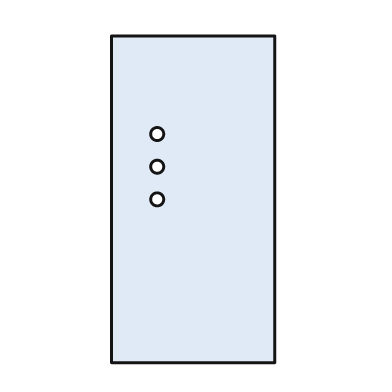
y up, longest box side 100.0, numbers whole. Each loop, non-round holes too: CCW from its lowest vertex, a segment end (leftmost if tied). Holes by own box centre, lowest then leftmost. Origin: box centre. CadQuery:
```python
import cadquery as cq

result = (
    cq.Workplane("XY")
    .moveTo(-25.0, -50.0)
    .lineTo(25.0, -50.0)
    .lineTo(25.0, 50.0)
    .lineTo(-25.0, 50.0)
    .close()
    .moveTo(-11.0, 0.0)
    .circle(2.0)
    .moveTo(-11.0, 10.0)
    .circle(2.0)
    .moveTo(-11.0, 20.0)
    .circle(2.0)
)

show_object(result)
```